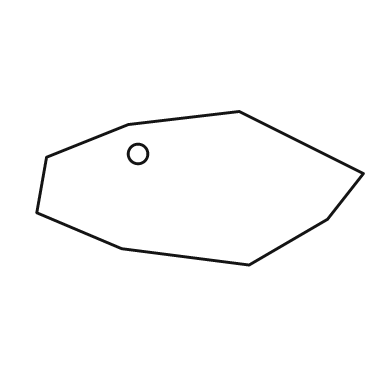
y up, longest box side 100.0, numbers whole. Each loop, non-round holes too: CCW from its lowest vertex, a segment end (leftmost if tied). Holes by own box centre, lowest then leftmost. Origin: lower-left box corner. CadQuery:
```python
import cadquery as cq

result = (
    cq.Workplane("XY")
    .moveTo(65.0, 0.0)
    .lineTo(89.0, 14.0)
    .lineTo(100.0, 28.0)
    .lineTo(62.0, 47.0)
    .lineTo(28.0, 43.0)
    .lineTo(3.0, 33.0)
    .lineTo(0.0, 16.0)
    .lineTo(26.0, 5.0)
    .close()
    .moveTo(31.0, 34.0)
    .circle(3.0)
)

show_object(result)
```